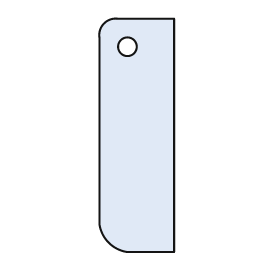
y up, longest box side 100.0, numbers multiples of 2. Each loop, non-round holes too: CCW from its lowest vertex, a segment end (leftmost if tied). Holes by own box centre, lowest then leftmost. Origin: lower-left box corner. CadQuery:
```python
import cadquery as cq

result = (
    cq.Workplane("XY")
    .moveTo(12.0, 0.0)
    .lineTo(32.0, 0.0)
    .lineTo(32.0, 100.0)
    .lineTo(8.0, 100.0)
    .threePointArc((2.0, 98.0), (0.0, 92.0))
    .lineTo(0.0, 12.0)
    .threePointArc((4.0, 4.0), (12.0, 0.0))
    .close()
    .moveTo(12.0, 88.0)
    .circle(4.0)
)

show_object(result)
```